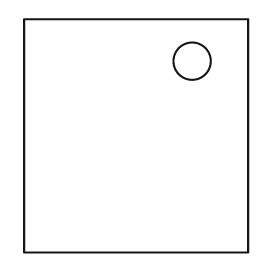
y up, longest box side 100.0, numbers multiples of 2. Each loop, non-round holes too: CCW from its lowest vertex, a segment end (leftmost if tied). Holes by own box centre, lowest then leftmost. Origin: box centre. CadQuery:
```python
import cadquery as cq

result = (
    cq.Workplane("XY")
    .moveTo(-48.0, -50.0)
    .lineTo(48.0, -50.0)
    .lineTo(48.0, 50.0)
    .lineTo(-48.0, 50.0)
    .close()
    .moveTo(24.0, 32.0)
    .circle(8.0)
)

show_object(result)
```